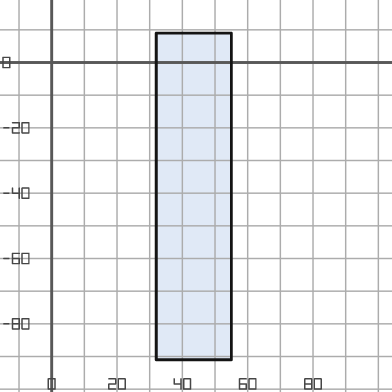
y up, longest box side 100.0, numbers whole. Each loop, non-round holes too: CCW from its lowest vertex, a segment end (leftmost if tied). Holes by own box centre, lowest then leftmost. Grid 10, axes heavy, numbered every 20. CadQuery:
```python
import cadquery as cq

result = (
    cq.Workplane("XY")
    .moveTo(32.0, -91.0)
    .lineTo(55.0, -91.0)
    .lineTo(55.0, 9.0)
    .lineTo(32.0, 9.0)
    .close()
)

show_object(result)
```